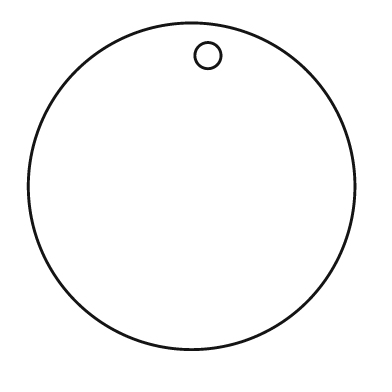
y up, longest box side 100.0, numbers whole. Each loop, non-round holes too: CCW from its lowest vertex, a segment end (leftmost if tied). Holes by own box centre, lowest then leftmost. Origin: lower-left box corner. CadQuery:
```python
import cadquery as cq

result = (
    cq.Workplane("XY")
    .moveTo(50.0, 50.0)
    .circle(50.0)
    .moveTo(55.0, 90.0)
    .circle(4.0)
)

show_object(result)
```